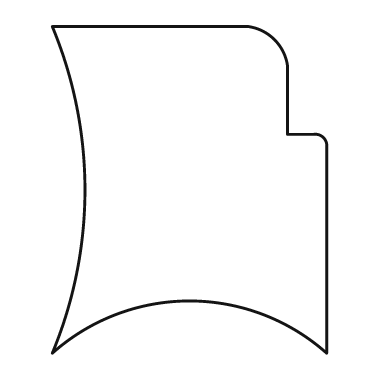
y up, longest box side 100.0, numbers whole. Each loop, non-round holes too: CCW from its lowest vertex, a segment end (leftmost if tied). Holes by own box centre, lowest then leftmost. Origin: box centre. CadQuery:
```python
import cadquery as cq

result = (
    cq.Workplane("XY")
    .moveTo(-42.0, -50.0)
    .threePointArc((0.0, -34.0), (42.0, -50.0))
    .lineTo(42.0, 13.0)
    .threePointArc((41.0, 16.0), (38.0, 17.0))
    .lineTo(30.0, 17.0)
    .lineTo(30.0, 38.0)
    .threePointArc((26.0, 46.0), (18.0, 50.0))
    .lineTo(-42.0, 50.0)
    .threePointArc((-32.0, 0.0), (-42.0, -50.0))
    .close()
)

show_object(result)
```